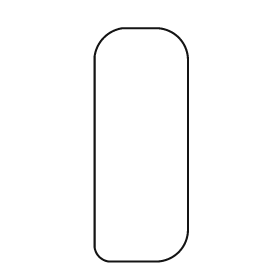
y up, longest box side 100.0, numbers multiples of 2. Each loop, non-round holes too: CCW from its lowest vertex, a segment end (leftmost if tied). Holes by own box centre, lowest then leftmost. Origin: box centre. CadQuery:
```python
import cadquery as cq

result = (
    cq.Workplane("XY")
    .moveTo(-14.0, -50.0)
    .lineTo(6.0, -50.0)
    .threePointArc((16.0, -46.0), (20.0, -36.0))
    .lineTo(20.0, 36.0)
    .threePointArc((16.0, 46.0), (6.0, 50.0))
    .lineTo(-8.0, 50.0)
    .threePointArc((-16.0, 46.0), (-20.0, 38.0))
    .lineTo(-20.0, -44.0)
    .threePointArc((-18.0, -48.0), (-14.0, -50.0))
    .close()
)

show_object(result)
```